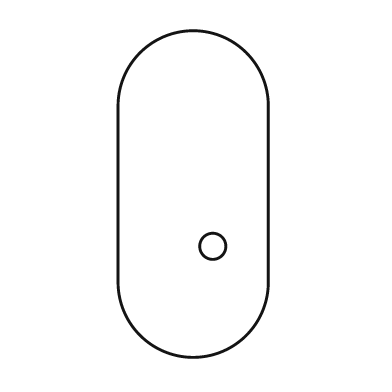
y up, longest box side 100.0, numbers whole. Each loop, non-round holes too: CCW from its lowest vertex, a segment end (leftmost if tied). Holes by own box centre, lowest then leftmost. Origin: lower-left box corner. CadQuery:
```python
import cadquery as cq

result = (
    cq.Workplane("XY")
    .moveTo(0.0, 23.0)
    .threePointArc((23.0, 0.0), (46.0, 23.0))
    .lineTo(46.0, 77.0)
    .threePointArc((23.0, 100.0), (0.0, 77.0))
    .close()
    .moveTo(29.0, 34.0)
    .circle(4.0)
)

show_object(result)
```